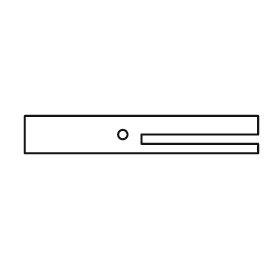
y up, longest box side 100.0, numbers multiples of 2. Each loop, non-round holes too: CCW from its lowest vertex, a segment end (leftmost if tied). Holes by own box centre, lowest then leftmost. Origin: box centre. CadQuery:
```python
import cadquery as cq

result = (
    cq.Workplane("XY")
    .moveTo(-50.0, -8.0)
    .lineTo(50.0, -8.0)
    .lineTo(50.0, -4.0)
    .lineTo(0.0, -4.0)
    .lineTo(0.0, 0.0)
    .lineTo(50.0, 0.0)
    .lineTo(50.0, 8.0)
    .lineTo(-50.0, 8.0)
    .close()
    .moveTo(-8.0, 0.0)
    .circle(2.0)
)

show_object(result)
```